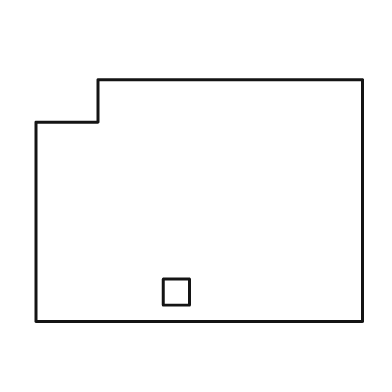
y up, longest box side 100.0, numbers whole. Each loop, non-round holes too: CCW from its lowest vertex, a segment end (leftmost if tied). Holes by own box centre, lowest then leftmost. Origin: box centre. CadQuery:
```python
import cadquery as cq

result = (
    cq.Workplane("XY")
    .moveTo(-50.0, -37.0)
    .lineTo(50.0, -37.0)
    .lineTo(50.0, 37.0)
    .lineTo(-31.0, 37.0)
    .lineTo(-31.0, 24.0)
    .lineTo(-50.0, 24.0)
    .close()
    .moveTo(-11.0, -32.0)
    .lineTo(-3.0, -32.0)
    .lineTo(-3.0, -24.0)
    .lineTo(-11.0, -24.0)
    .close()
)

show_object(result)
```